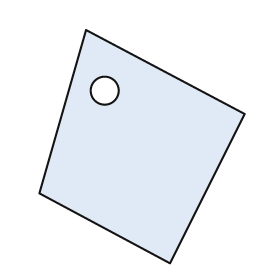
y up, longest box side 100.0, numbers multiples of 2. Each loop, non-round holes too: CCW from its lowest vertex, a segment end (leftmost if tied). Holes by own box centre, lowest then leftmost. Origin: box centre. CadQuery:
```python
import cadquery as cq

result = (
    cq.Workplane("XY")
    .moveTo(12.0, -50.0)
    .lineTo(44.0, 14.0)
    .lineTo(-24.0, 50.0)
    .lineTo(-44.0, -20.0)
    .close()
    .moveTo(-16.0, 24.0)
    .circle(6.0)
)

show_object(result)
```